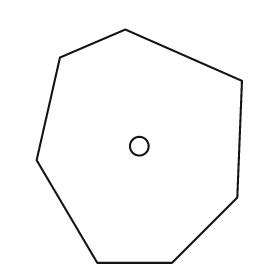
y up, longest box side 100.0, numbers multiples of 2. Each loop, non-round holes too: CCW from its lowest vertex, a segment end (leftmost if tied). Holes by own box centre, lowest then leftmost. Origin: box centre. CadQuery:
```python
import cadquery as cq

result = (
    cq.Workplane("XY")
    .moveTo(-18.0, -50.0)
    .lineTo(14.0, -50.0)
    .lineTo(42.0, -22.0)
    .lineTo(44.0, 28.0)
    .lineTo(-6.0, 50.0)
    .lineTo(-34.0, 38.0)
    .lineTo(-44.0, -6.0)
    .close()
    .moveTo(0.0, 0.0)
    .circle(4.0)
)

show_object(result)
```